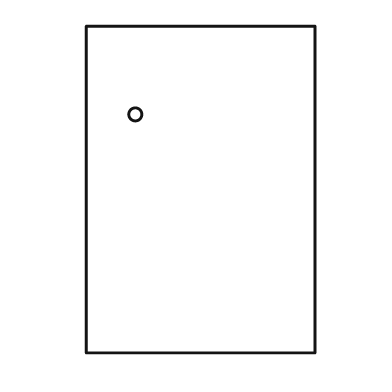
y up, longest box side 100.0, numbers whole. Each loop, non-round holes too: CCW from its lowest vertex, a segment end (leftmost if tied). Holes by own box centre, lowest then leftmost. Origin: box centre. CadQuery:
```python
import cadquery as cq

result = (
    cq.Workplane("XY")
    .moveTo(-35.0, -50.0)
    .lineTo(35.0, -50.0)
    .lineTo(35.0, 50.0)
    .lineTo(-35.0, 50.0)
    .close()
    .moveTo(-20.0, 23.0)
    .circle(2.0)
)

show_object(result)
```